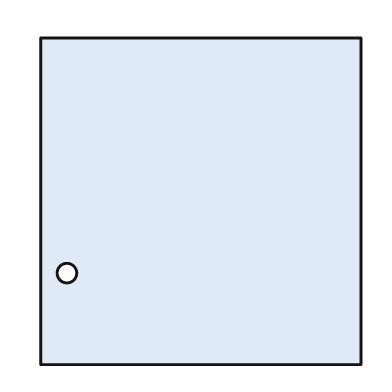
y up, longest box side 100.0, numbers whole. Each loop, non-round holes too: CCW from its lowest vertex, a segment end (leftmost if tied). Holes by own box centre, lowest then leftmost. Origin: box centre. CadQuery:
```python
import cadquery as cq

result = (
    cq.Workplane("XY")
    .moveTo(-49.0, -50.0)
    .lineTo(49.0, -50.0)
    .lineTo(49.0, 50.0)
    .lineTo(-49.0, 50.0)
    .close()
    .moveTo(-41.0, -22.0)
    .circle(3.0)
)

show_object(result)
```